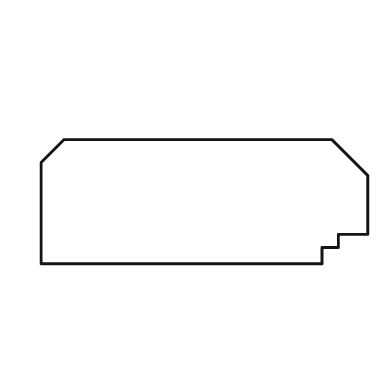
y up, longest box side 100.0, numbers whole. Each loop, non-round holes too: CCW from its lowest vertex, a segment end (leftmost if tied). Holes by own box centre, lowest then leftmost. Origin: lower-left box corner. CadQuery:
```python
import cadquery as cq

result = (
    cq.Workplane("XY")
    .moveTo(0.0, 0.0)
    .lineTo(86.0, 0.0)
    .lineTo(86.0, 5.0)
    .lineTo(91.0, 5.0)
    .lineTo(91.0, 9.0)
    .lineTo(100.0, 9.0)
    .lineTo(100.0, 27.0)
    .lineTo(89.0, 38.0)
    .lineTo(7.0, 38.0)
    .lineTo(0.0, 31.0)
    .close()
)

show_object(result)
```